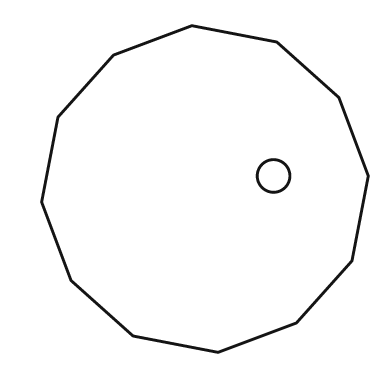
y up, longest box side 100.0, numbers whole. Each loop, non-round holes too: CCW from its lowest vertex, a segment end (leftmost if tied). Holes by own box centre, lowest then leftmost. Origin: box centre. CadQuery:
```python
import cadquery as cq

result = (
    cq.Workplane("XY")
    .moveTo(4.0, -50.0)
    .lineTo(28.0, -41.0)
    .lineTo(45.0, -22.0)
    .lineTo(50.0, 4.0)
    .lineTo(41.0, 28.0)
    .lineTo(22.0, 45.0)
    .lineTo(-4.0, 50.0)
    .lineTo(-28.0, 41.0)
    .lineTo(-45.0, 22.0)
    .lineTo(-50.0, -4.0)
    .lineTo(-41.0, -28.0)
    .lineTo(-22.0, -45.0)
    .close()
    .moveTo(21.0, 4.0)
    .circle(5.0)
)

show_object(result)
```